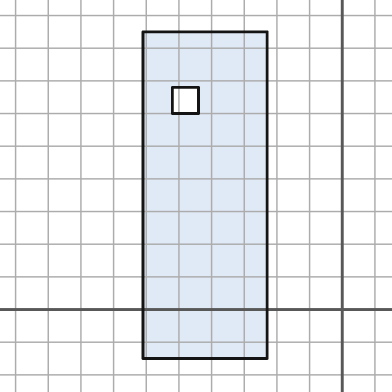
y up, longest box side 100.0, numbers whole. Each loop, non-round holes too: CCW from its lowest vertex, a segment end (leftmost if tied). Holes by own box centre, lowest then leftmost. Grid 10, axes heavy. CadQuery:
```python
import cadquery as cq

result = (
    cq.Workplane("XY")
    .moveTo(-61.0, -15.0)
    .lineTo(-23.0, -15.0)
    .lineTo(-23.0, 85.0)
    .lineTo(-61.0, 85.0)
    .close()
    .moveTo(-52.0, 60.0)
    .lineTo(-44.0, 60.0)
    .lineTo(-44.0, 68.0)
    .lineTo(-52.0, 68.0)
    .close()
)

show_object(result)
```